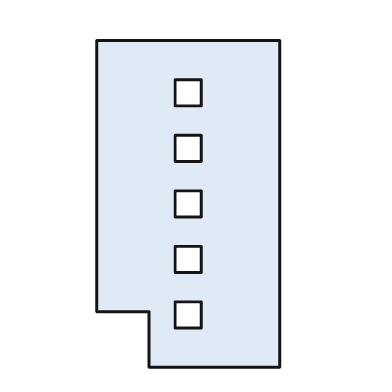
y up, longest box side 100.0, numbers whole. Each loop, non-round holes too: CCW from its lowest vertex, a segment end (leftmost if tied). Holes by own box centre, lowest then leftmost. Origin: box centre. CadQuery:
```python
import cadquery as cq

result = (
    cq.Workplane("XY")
    .moveTo(-12.0, -50.0)
    .lineTo(28.0, -50.0)
    .lineTo(28.0, 50.0)
    .lineTo(-28.0, 50.0)
    .lineTo(-28.0, -33.0)
    .lineTo(-12.0, -33.0)
    .close()
    .moveTo(-4.0, -38.0)
    .lineTo(4.0, -38.0)
    .lineTo(4.0, -30.0)
    .lineTo(-4.0, -30.0)
    .close()
    .moveTo(-4.0, -21.0)
    .lineTo(4.0, -21.0)
    .lineTo(4.0, -13.0)
    .lineTo(-4.0, -13.0)
    .close()
    .moveTo(-4.0, -4.0)
    .lineTo(4.0, -4.0)
    .lineTo(4.0, 4.0)
    .lineTo(-4.0, 4.0)
    .close()
    .moveTo(-4.0, 13.0)
    .lineTo(4.0, 13.0)
    .lineTo(4.0, 21.0)
    .lineTo(-4.0, 21.0)
    .close()
    .moveTo(-4.0, 30.0)
    .lineTo(4.0, 30.0)
    .lineTo(4.0, 38.0)
    .lineTo(-4.0, 38.0)
    .close()
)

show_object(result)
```